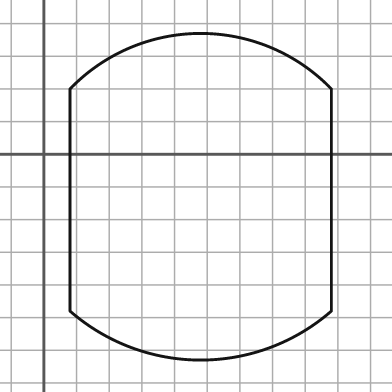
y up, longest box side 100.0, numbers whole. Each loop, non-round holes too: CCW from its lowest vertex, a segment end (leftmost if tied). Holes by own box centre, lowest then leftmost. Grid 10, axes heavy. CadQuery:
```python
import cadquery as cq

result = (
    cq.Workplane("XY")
    .moveTo(8.0, -48.0)
    .threePointArc((48.0, -63.0), (88.0, -48.0))
    .lineTo(88.0, 20.0)
    .threePointArc((48.0, 37.0), (8.0, 20.0))
    .close()
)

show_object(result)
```